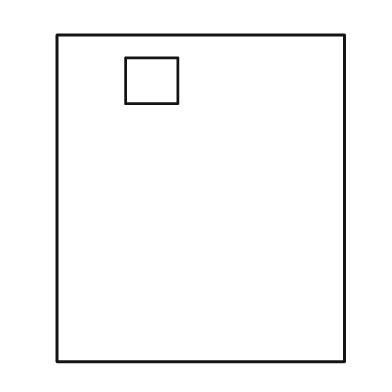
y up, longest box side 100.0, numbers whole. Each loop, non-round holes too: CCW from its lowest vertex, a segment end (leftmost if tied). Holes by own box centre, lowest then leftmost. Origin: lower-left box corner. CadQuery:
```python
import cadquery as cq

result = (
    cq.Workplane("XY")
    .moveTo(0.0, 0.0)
    .lineTo(88.0, 0.0)
    .lineTo(88.0, 100.0)
    .lineTo(0.0, 100.0)
    .close()
    .moveTo(21.0, 79.0)
    .lineTo(37.0, 79.0)
    .lineTo(37.0, 93.0)
    .lineTo(21.0, 93.0)
    .close()
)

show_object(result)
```